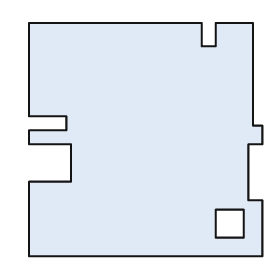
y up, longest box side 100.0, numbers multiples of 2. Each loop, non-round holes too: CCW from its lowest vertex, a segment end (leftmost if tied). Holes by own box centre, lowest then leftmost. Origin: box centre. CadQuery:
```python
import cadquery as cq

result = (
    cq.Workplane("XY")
    .moveTo(-50.0, -50.0)
    .lineTo(50.0, -50.0)
    .lineTo(50.0, -26.0)
    .lineTo(44.0, -26.0)
    .lineTo(44.0, -2.0)
    .lineTo(50.0, -2.0)
    .lineTo(50.0, 6.0)
    .lineTo(46.0, 6.0)
    .lineTo(46.0, 50.0)
    .lineTo(30.0, 50.0)
    .lineTo(30.0, 40.0)
    .lineTo(24.0, 40.0)
    .lineTo(24.0, 50.0)
    .lineTo(-50.0, 50.0)
    .lineTo(-50.0, 10.0)
    .lineTo(-34.0, 10.0)
    .lineTo(-34.0, 4.0)
    .lineTo(-50.0, 4.0)
    .lineTo(-50.0, -2.0)
    .lineTo(-32.0, -2.0)
    .lineTo(-32.0, -18.0)
    .lineTo(-50.0, -18.0)
    .close()
    .moveTo(30.0, -42.0)
    .lineTo(42.0, -42.0)
    .lineTo(42.0, -30.0)
    .lineTo(30.0, -30.0)
    .close()
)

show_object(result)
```